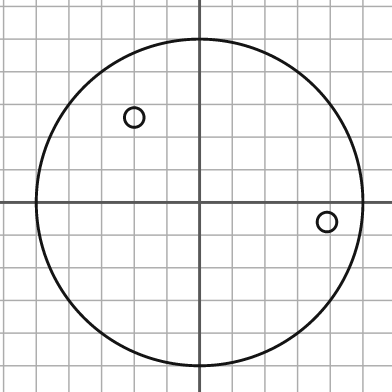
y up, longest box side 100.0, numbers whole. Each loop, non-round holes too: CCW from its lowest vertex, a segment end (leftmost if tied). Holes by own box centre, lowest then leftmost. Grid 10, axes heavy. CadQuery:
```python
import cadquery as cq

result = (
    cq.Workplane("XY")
    .moveTo(0.0, 0.0)
    .circle(50.0)
    .moveTo(39.0, -6.0)
    .circle(3.0)
    .moveTo(-20.0, 26.0)
    .circle(3.0)
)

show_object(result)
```